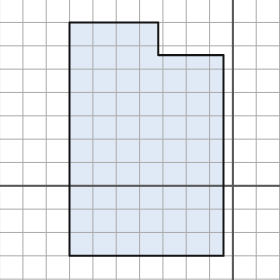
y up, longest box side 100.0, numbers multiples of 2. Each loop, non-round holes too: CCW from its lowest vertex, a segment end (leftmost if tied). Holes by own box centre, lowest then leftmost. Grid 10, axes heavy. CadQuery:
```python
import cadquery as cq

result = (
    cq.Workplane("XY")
    .moveTo(-70.0, -30.0)
    .lineTo(-4.0, -30.0)
    .lineTo(-4.0, 56.0)
    .lineTo(-32.0, 56.0)
    .lineTo(-32.0, 70.0)
    .lineTo(-70.0, 70.0)
    .close()
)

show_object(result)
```